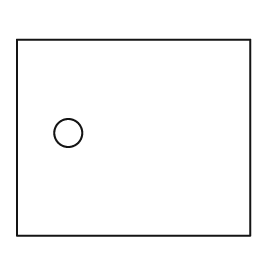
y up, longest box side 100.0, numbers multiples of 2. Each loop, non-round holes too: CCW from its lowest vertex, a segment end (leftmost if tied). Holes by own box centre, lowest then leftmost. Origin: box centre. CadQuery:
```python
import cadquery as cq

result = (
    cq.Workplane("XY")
    .moveTo(-50.0, -42.0)
    .lineTo(50.0, -42.0)
    .lineTo(50.0, 42.0)
    .lineTo(-50.0, 42.0)
    .close()
    .moveTo(-28.0, 2.0)
    .circle(6.0)
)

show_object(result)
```